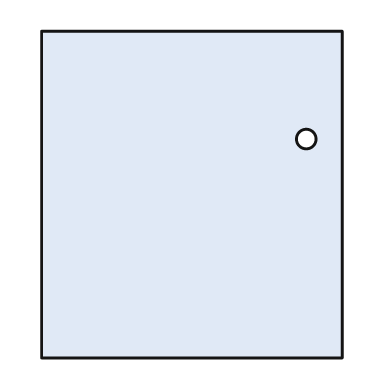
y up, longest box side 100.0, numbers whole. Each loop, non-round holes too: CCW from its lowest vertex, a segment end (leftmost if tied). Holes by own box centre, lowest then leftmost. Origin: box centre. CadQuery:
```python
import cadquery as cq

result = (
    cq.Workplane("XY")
    .moveTo(-46.0, -50.0)
    .lineTo(46.0, -50.0)
    .lineTo(46.0, 50.0)
    .lineTo(-46.0, 50.0)
    .close()
    .moveTo(35.0, 17.0)
    .circle(3.0)
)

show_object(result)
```